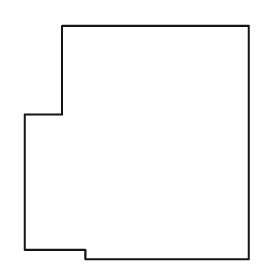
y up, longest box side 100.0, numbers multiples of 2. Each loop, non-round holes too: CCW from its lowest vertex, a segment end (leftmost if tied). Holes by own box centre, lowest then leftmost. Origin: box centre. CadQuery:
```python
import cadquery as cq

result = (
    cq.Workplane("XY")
    .moveTo(-22.0, -50.0)
    .lineTo(48.0, -50.0)
    .lineTo(48.0, 50.0)
    .lineTo(-32.0, 50.0)
    .lineTo(-32.0, 12.0)
    .lineTo(-48.0, 12.0)
    .lineTo(-48.0, -46.0)
    .lineTo(-22.0, -46.0)
    .close()
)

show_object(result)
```